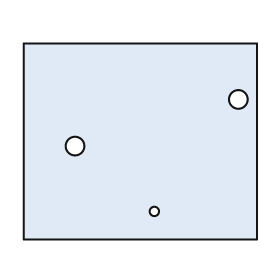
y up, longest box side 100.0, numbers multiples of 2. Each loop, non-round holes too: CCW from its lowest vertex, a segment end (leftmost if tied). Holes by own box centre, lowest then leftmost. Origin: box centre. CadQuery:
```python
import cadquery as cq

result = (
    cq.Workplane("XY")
    .moveTo(-50.0, -42.0)
    .lineTo(50.0, -42.0)
    .lineTo(50.0, 42.0)
    .lineTo(-50.0, 42.0)
    .close()
    .moveTo(6.0, -30.0)
    .circle(2.0)
    .moveTo(-28.0, -2.0)
    .circle(4.0)
    .moveTo(42.0, 18.0)
    .circle(4.0)
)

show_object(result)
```